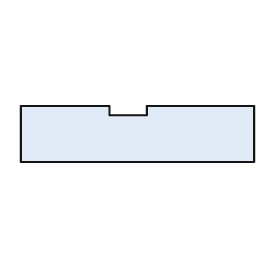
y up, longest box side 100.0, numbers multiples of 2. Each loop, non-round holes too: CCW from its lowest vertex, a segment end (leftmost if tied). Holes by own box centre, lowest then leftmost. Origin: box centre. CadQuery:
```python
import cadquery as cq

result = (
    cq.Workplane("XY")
    .moveTo(-50.0, -12.0)
    .lineTo(50.0, -12.0)
    .lineTo(50.0, 12.0)
    .lineTo(4.0, 12.0)
    .lineTo(4.0, 8.0)
    .lineTo(-12.0, 8.0)
    .lineTo(-12.0, 12.0)
    .lineTo(-50.0, 12.0)
    .close()
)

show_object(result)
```